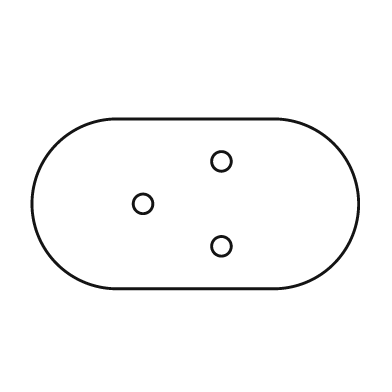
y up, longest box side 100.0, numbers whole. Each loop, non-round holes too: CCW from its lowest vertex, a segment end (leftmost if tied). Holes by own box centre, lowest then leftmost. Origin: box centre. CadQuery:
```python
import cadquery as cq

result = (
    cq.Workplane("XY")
    .moveTo(-24.0, -26.0)
    .lineTo(24.0, -26.0)
    .threePointArc((50.0, 0.0), (24.0, 26.0))
    .lineTo(-24.0, 26.0)
    .threePointArc((-50.0, 0.0), (-24.0, -26.0))
    .close()
    .moveTo(8.0, -13.0)
    .circle(3.0)
    .moveTo(-16.0, 0.0)
    .circle(3.0)
    .moveTo(8.0, 13.0)
    .circle(3.0)
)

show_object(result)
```